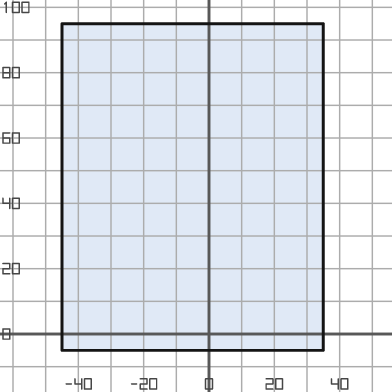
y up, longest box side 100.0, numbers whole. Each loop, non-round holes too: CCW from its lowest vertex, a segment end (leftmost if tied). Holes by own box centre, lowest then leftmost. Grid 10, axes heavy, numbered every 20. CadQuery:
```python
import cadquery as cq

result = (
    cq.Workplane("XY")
    .moveTo(-45.0, -5.0)
    .lineTo(35.0, -5.0)
    .lineTo(35.0, 95.0)
    .lineTo(-45.0, 95.0)
    .close()
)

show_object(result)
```